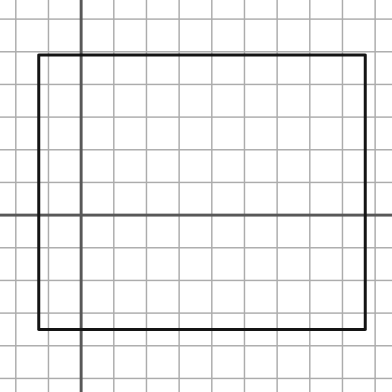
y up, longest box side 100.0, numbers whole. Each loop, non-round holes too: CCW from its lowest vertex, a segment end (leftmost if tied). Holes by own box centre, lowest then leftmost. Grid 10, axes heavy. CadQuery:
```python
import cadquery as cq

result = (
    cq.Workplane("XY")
    .moveTo(-13.0, -35.0)
    .lineTo(87.0, -35.0)
    .lineTo(87.0, 49.0)
    .lineTo(-13.0, 49.0)
    .close()
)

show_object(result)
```